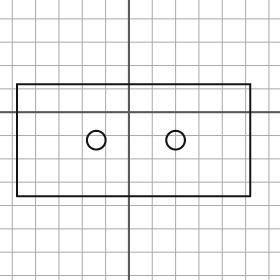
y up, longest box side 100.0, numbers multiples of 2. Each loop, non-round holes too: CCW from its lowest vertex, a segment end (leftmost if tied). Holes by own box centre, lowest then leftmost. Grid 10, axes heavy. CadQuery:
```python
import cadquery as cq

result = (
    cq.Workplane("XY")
    .moveTo(-48.0, -36.0)
    .lineTo(52.0, -36.0)
    .lineTo(52.0, 12.0)
    .lineTo(-48.0, 12.0)
    .close()
    .moveTo(-14.0, -12.0)
    .circle(4.0)
    .moveTo(20.0, -12.0)
    .circle(4.0)
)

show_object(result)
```